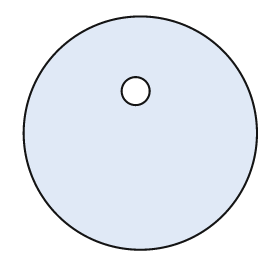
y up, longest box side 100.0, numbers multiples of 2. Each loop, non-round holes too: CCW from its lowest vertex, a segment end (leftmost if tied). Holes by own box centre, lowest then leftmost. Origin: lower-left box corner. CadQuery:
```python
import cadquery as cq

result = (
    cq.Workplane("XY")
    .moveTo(50.0, 50.0)
    .circle(50.0)
    .moveTo(48.0, 68.0)
    .circle(6.0)
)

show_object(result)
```